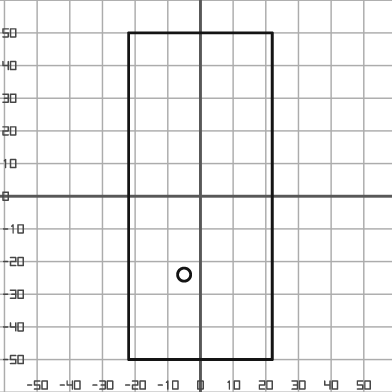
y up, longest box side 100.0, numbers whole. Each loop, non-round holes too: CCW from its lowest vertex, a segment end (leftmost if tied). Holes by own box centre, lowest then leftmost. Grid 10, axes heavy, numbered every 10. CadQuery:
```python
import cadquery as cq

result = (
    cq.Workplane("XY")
    .moveTo(-22.0, -50.0)
    .lineTo(22.0, -50.0)
    .lineTo(22.0, 50.0)
    .lineTo(-22.0, 50.0)
    .close()
    .moveTo(-5.0, -24.0)
    .circle(2.0)
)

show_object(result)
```